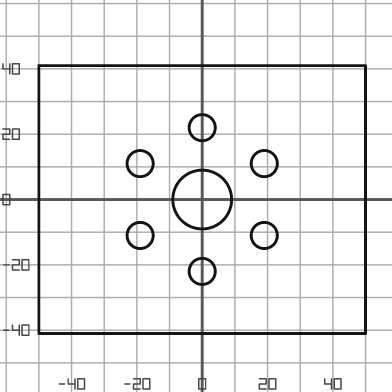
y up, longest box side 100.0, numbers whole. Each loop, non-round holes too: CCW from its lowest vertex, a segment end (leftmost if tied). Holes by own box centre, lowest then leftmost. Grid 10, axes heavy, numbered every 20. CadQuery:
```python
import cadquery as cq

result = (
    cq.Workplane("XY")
    .moveTo(-50.0, -41.0)
    .lineTo(50.0, -41.0)
    .lineTo(50.0, 41.0)
    .lineTo(-50.0, 41.0)
    .close()
    .moveTo(0.0, -22.0)
    .circle(4.0)
    .moveTo(-19.0, -11.0)
    .circle(4.0)
    .moveTo(19.0, -11.0)
    .circle(4.0)
    .moveTo(0.0, 0.0)
    .circle(9.0)
    .moveTo(-19.0, 11.0)
    .circle(4.0)
    .moveTo(19.0, 11.0)
    .circle(4.0)
    .moveTo(0.0, 22.0)
    .circle(4.0)
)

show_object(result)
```